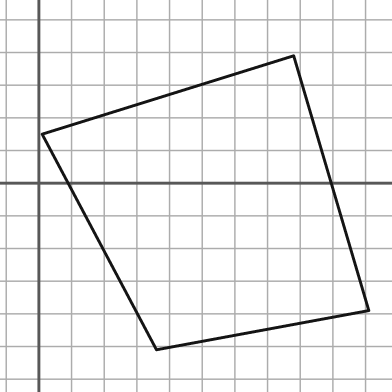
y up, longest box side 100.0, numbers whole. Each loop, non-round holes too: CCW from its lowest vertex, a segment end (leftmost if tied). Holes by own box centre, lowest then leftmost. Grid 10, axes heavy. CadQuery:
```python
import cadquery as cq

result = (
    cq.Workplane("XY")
    .moveTo(36.0, -51.0)
    .lineTo(101.0, -39.0)
    .lineTo(78.0, 39.0)
    .lineTo(1.0, 15.0)
    .close()
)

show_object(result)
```